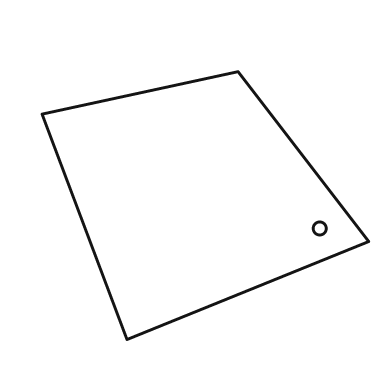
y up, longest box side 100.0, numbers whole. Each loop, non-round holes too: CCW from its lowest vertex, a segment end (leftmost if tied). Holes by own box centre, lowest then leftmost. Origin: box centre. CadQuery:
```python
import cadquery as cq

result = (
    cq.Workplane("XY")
    .moveTo(-24.0, -41.0)
    .lineTo(50.0, -11.0)
    .lineTo(10.0, 41.0)
    .lineTo(-50.0, 28.0)
    .close()
    .moveTo(35.0, -7.0)
    .circle(2.0)
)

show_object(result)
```